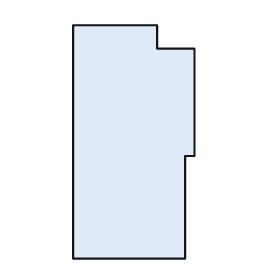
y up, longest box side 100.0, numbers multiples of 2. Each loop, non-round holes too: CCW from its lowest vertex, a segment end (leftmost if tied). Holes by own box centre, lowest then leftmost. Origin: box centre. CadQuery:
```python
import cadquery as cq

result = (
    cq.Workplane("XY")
    .moveTo(-26.0, -50.0)
    .lineTo(22.0, -50.0)
    .lineTo(22.0, -6.0)
    .lineTo(26.0, -6.0)
    .lineTo(26.0, 40.0)
    .lineTo(10.0, 40.0)
    .lineTo(10.0, 50.0)
    .lineTo(-26.0, 50.0)
    .close()
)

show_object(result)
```